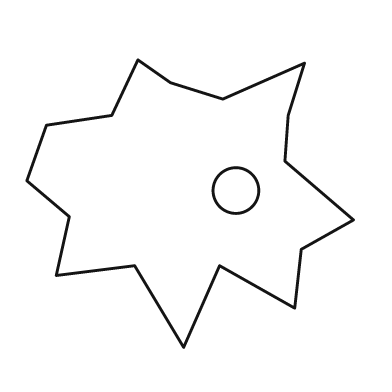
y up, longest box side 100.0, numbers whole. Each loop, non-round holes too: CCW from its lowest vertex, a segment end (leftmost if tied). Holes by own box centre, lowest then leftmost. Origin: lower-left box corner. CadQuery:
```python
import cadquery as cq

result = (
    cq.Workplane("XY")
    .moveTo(48.0, 0.0)
    .lineTo(59.0, 25.0)
    .lineTo(82.0, 12.0)
    .lineTo(84.0, 30.0)
    .lineTo(100.0, 39.0)
    .lineTo(79.0, 57.0)
    .lineTo(80.0, 71.0)
    .lineTo(85.0, 87.0)
    .lineTo(60.0, 76.0)
    .lineTo(44.0, 81.0)
    .lineTo(34.0, 88.0)
    .lineTo(26.0, 71.0)
    .lineTo(6.0, 68.0)
    .lineTo(0.0, 51.0)
    .lineTo(13.0, 40.0)
    .lineTo(9.0, 22.0)
    .lineTo(33.0, 25.0)
    .close()
    .moveTo(64.0, 48.0)
    .circle(7.0)
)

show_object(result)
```